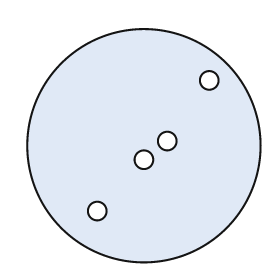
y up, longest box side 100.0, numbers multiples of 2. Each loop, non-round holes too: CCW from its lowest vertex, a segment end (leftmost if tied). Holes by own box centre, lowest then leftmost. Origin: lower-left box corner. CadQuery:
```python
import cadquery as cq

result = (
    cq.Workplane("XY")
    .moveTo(50.0, 50.0)
    .circle(50.0)
    .moveTo(30.0, 22.0)
    .circle(4.0)
    .moveTo(50.0, 44.0)
    .circle(4.0)
    .moveTo(60.0, 52.0)
    .circle(4.0)
    .moveTo(78.0, 78.0)
    .circle(4.0)
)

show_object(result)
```